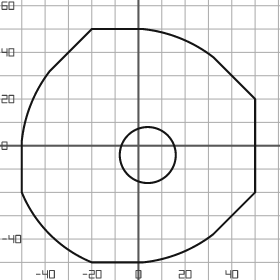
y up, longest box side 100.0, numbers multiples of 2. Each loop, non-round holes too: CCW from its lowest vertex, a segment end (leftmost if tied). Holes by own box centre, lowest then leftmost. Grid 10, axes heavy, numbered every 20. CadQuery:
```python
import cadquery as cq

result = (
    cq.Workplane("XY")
    .moveTo(-20.0, -50.0)
    .lineTo(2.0, -50.0)
    .threePointArc((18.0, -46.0), (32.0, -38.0))
    .lineTo(50.0, -20.0)
    .lineTo(50.0, 20.0)
    .lineTo(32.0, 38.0)
    .threePointArc((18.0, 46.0), (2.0, 50.0))
    .lineTo(-20.0, 50.0)
    .lineTo(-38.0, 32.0)
    .threePointArc((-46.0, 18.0), (-50.0, 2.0))
    .lineTo(-50.0, -20.0)
    .threePointArc((-38.0, -38.0), (-20.0, -50.0))
    .close()
    .moveTo(4.0, -4.0)
    .circle(12.0)
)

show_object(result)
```